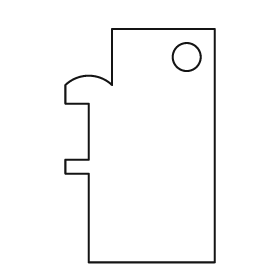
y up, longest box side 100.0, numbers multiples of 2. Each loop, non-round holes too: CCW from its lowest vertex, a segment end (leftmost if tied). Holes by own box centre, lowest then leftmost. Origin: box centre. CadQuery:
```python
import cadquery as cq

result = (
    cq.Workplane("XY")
    .moveTo(-22.0, -50.0)
    .lineTo(32.0, -50.0)
    .lineTo(32.0, 50.0)
    .lineTo(-12.0, 50.0)
    .lineTo(-12.0, 26.0)
    .threePointArc((-22.0, 30.0), (-32.0, 26.0))
    .lineTo(-32.0, 18.0)
    .lineTo(-22.0, 18.0)
    .lineTo(-22.0, -6.0)
    .lineTo(-32.0, -6.0)
    .lineTo(-32.0, -12.0)
    .lineTo(-22.0, -12.0)
    .close()
    .moveTo(20.0, 38.0)
    .circle(6.0)
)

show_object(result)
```